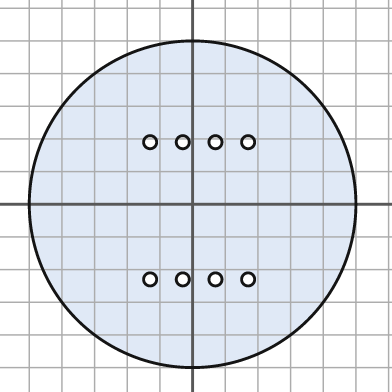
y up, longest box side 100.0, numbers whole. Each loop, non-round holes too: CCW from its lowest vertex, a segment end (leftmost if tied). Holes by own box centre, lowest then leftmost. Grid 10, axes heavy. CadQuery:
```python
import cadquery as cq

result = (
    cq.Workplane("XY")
    .moveTo(0.0, 0.0)
    .circle(50.0)
    .moveTo(-13.0, -23.0)
    .circle(2.0)
    .moveTo(-3.0, -23.0)
    .circle(2.0)
    .moveTo(7.0, -23.0)
    .circle(2.0)
    .moveTo(17.0, -23.0)
    .circle(2.0)
    .moveTo(-13.0, 19.0)
    .circle(2.0)
    .moveTo(-3.0, 19.0)
    .circle(2.0)
    .moveTo(7.0, 19.0)
    .circle(2.0)
    .moveTo(17.0, 19.0)
    .circle(2.0)
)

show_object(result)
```